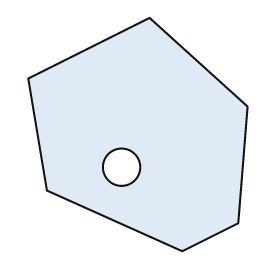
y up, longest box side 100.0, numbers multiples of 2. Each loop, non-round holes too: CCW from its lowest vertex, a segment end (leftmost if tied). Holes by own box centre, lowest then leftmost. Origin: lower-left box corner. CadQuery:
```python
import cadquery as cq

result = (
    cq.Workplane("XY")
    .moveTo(66.0, 0.0)
    .lineTo(90.0, 12.0)
    .lineTo(94.0, 62.0)
    .lineTo(52.0, 100.0)
    .lineTo(0.0, 74.0)
    .lineTo(8.0, 26.0)
    .close()
    .moveTo(40.0, 36.0)
    .circle(8.0)
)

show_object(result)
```